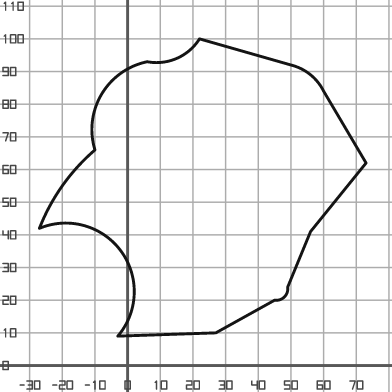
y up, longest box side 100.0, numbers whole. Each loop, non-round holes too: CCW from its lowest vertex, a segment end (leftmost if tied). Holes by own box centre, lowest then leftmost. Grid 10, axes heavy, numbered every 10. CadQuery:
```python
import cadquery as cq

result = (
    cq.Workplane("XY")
    .moveTo(-3.0, 9.0)
    .lineTo(27.0, 10.0)
    .lineTo(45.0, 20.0)
    .threePointArc((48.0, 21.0), (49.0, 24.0))
    .lineTo(56.0, 41.0)
    .lineTo(73.0, 62.0)
    .lineTo(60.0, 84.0)
    .threePointArc((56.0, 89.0), (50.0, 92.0))
    .lineTo(22.0, 100.0)
    .threePointArc((15.0, 94.0), (6.0, 93.0))
    .threePointArc((-8.0, 83.0), (-10.0, 66.0))
    .threePointArc((-20.0, 55.0), (-27.0, 42.0))
    .threePointArc((-2.0, 35.0), (-3.0, 9.0))
    .close()
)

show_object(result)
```